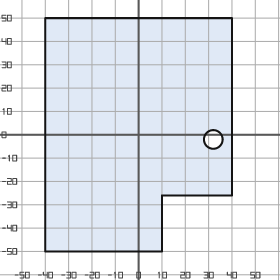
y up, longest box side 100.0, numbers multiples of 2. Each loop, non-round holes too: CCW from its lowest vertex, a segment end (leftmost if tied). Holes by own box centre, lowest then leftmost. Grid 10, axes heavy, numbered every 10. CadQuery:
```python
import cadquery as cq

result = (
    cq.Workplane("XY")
    .moveTo(-40.0, -50.0)
    .lineTo(10.0, -50.0)
    .lineTo(10.0, -26.0)
    .lineTo(40.0, -26.0)
    .lineTo(40.0, 50.0)
    .lineTo(-40.0, 50.0)
    .close()
    .moveTo(32.0, -2.0)
    .circle(4.0)
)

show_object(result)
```